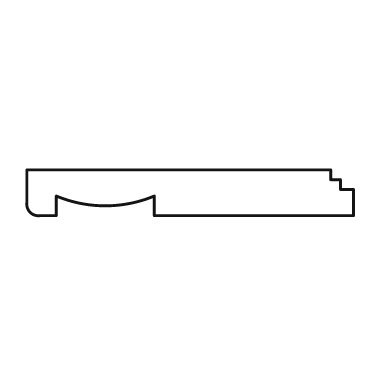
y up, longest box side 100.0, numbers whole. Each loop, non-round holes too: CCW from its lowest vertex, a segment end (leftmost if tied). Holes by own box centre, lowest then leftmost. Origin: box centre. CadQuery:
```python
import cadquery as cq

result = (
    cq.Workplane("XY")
    .moveTo(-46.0, -7.0)
    .lineTo(-41.0, -7.0)
    .lineTo(-41.0, -1.0)
    .threePointArc((-26.0, -4.0), (-11.0, -1.0))
    .lineTo(-11.0, -7.0)
    .lineTo(50.0, -7.0)
    .lineTo(50.0, 1.0)
    .lineTo(46.0, 1.0)
    .lineTo(46.0, 4.0)
    .lineTo(43.0, 4.0)
    .lineTo(43.0, 7.0)
    .lineTo(-50.0, 7.0)
    .lineTo(-50.0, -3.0)
    .threePointArc((-49.0, -6.0), (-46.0, -7.0))
    .close()
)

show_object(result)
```